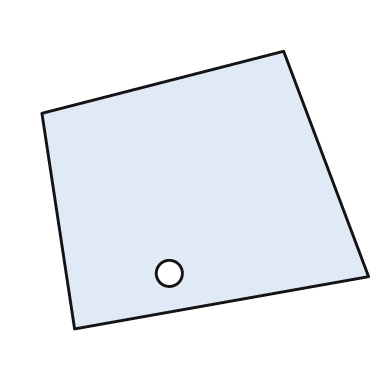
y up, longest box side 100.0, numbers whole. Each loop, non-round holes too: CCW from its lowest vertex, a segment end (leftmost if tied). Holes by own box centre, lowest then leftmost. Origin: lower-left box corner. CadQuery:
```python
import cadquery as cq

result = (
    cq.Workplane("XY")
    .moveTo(10.0, 0.0)
    .lineTo(100.0, 16.0)
    .lineTo(74.0, 85.0)
    .lineTo(0.0, 66.0)
    .close()
    .moveTo(39.0, 17.0)
    .circle(4.0)
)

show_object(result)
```